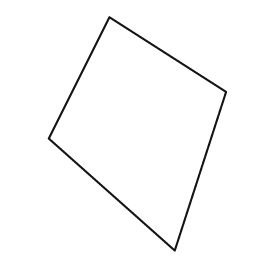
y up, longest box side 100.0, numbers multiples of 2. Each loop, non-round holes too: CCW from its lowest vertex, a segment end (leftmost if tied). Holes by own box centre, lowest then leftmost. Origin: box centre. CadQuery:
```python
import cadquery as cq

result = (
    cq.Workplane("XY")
    .moveTo(16.0, -50.0)
    .lineTo(38.0, 18.0)
    .lineTo(-12.0, 50.0)
    .lineTo(-38.0, -2.0)
    .close()
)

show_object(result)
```